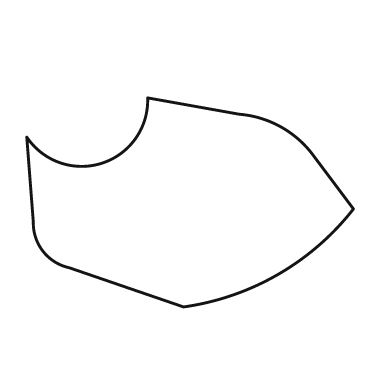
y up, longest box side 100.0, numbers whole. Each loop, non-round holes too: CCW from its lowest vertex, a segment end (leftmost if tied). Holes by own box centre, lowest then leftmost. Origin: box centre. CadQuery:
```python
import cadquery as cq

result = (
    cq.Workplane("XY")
    .moveTo(-2.0, -32.0)
    .threePointArc((27.0, -22.0), (50.0, -2.0))
    .lineTo(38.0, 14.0)
    .threePointArc((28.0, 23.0), (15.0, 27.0))
    .lineTo(-13.0, 32.0)
    .threePointArc((-27.0, 12.0), (-50.0, 20.0))
    .lineTo(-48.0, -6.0)
    .threePointArc((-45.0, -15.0), (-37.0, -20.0))
    .close()
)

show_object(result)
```